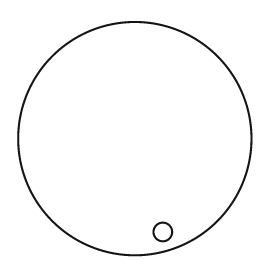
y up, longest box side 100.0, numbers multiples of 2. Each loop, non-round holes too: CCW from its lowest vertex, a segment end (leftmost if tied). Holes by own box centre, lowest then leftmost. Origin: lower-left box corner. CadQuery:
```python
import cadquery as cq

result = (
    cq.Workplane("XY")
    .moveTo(50.0, 50.0)
    .circle(50.0)
    .moveTo(62.0, 10.0)
    .circle(4.0)
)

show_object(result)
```